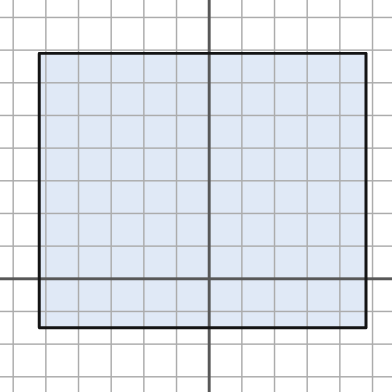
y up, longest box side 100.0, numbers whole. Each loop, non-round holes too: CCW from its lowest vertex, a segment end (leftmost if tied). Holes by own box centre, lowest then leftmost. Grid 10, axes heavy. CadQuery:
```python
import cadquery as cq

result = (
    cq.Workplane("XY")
    .moveTo(-52.0, -15.0)
    .lineTo(48.0, -15.0)
    .lineTo(48.0, 69.0)
    .lineTo(-52.0, 69.0)
    .close()
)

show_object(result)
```